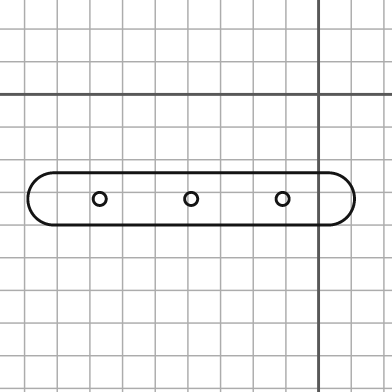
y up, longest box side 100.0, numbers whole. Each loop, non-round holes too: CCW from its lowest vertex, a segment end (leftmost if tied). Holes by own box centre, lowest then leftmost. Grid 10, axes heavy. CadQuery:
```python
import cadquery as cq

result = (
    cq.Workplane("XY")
    .moveTo(-81.0, -40.0)
    .lineTo(3.0, -40.0)
    .threePointArc((11.0, -32.0), (3.0, -24.0))
    .lineTo(-81.0, -24.0)
    .threePointArc((-89.0, -32.0), (-81.0, -40.0))
    .close()
    .moveTo(-67.0, -32.0)
    .circle(2.0)
    .moveTo(-39.0, -32.0)
    .circle(2.0)
    .moveTo(-11.0, -32.0)
    .circle(2.0)
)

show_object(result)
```